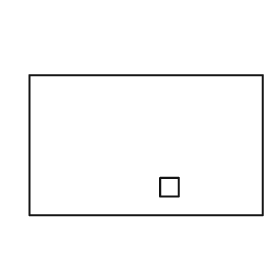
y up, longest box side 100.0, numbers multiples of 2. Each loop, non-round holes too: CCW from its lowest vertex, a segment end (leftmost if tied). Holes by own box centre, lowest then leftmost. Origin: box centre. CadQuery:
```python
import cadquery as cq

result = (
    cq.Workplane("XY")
    .moveTo(-50.0, -30.0)
    .lineTo(50.0, -30.0)
    .lineTo(50.0, 30.0)
    .lineTo(-50.0, 30.0)
    .close()
    .moveTo(6.0, -22.0)
    .lineTo(14.0, -22.0)
    .lineTo(14.0, -14.0)
    .lineTo(6.0, -14.0)
    .close()
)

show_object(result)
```